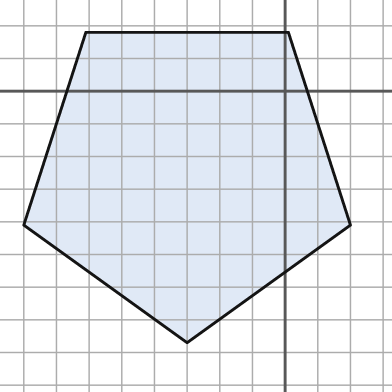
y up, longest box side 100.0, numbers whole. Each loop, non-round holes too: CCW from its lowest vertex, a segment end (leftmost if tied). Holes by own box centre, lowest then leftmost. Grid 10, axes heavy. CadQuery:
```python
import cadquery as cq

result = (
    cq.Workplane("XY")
    .moveTo(-30.0, -77.0)
    .lineTo(20.0, -41.0)
    .lineTo(1.0, 18.0)
    .lineTo(-61.0, 18.0)
    .lineTo(-80.0, -41.0)
    .close()
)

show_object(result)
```